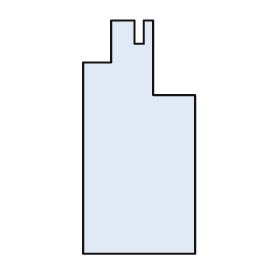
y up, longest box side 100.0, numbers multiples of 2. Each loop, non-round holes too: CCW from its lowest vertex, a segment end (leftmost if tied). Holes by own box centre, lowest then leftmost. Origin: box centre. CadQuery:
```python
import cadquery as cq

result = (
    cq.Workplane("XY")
    .moveTo(-24.0, -50.0)
    .lineTo(24.0, -50.0)
    .lineTo(24.0, 18.0)
    .lineTo(6.0, 18.0)
    .lineTo(6.0, 50.0)
    .lineTo(2.0, 50.0)
    .lineTo(2.0, 40.0)
    .lineTo(-2.0, 40.0)
    .lineTo(-2.0, 50.0)
    .lineTo(-12.0, 50.0)
    .lineTo(-12.0, 32.0)
    .lineTo(-24.0, 32.0)
    .close()
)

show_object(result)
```